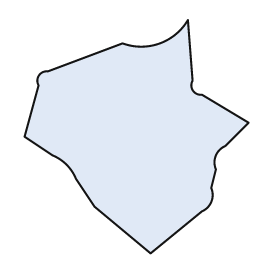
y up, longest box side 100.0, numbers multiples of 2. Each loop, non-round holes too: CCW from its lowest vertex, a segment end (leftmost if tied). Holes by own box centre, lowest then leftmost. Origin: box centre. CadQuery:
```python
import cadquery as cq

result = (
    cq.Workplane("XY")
    .moveTo(6.0, -50.0)
    .lineTo(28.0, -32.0)
    .threePointArc((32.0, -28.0), (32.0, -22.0))
    .lineTo(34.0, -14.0)
    .threePointArc((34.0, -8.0), (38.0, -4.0))
    .lineTo(48.0, 6.0)
    .lineTo(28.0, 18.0)
    .threePointArc((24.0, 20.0), (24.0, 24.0))
    .lineTo(22.0, 50.0)
    .threePointArc((10.0, 40.0), (-6.0, 40.0))
    .lineTo(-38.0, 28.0)
    .threePointArc((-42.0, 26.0), (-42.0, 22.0))
    .lineTo(-48.0, 0.0)
    .lineTo(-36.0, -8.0)
    .threePointArc((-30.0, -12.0), (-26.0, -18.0))
    .lineTo(-18.0, -30.0)
    .close()
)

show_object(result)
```